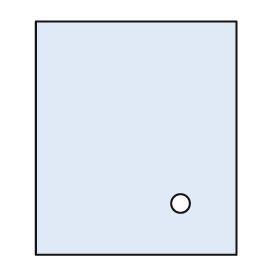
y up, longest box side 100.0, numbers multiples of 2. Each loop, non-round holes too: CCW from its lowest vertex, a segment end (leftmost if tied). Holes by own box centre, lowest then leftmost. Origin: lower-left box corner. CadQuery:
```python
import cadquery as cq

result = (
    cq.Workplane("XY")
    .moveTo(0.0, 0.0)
    .lineTo(86.0, 0.0)
    .lineTo(86.0, 100.0)
    .lineTo(0.0, 100.0)
    .close()
    .moveTo(62.0, 22.0)
    .circle(4.0)
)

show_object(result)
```